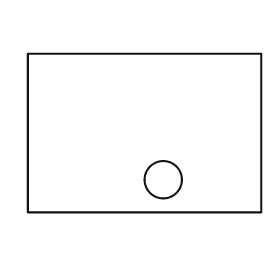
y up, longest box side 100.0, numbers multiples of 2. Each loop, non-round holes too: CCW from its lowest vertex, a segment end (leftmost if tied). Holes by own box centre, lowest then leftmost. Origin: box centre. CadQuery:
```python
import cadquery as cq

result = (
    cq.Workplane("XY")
    .moveTo(-50.0, -34.0)
    .lineTo(50.0, -34.0)
    .lineTo(50.0, 34.0)
    .lineTo(-50.0, 34.0)
    .close()
    .moveTo(8.0, -20.0)
    .circle(8.0)
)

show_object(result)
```